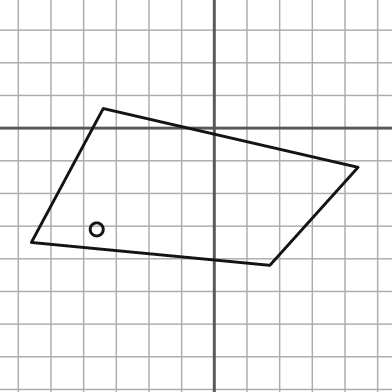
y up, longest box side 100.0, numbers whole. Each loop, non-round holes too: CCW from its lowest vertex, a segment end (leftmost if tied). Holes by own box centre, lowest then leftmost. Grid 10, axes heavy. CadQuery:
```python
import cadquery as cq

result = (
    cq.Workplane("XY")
    .moveTo(17.0, -42.0)
    .lineTo(44.0, -12.0)
    .lineTo(-34.0, 6.0)
    .lineTo(-56.0, -35.0)
    .close()
    .moveTo(-36.0, -31.0)
    .circle(2.0)
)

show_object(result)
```